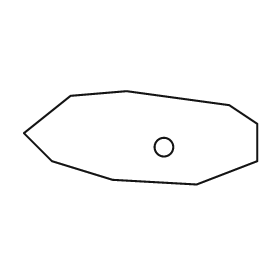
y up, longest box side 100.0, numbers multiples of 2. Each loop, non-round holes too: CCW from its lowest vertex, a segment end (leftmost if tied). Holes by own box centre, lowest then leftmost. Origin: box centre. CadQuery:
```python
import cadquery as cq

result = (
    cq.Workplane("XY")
    .moveTo(24.0, -20.0)
    .lineTo(50.0, -10.0)
    .lineTo(50.0, 6.0)
    .lineTo(38.0, 14.0)
    .lineTo(-6.0, 20.0)
    .lineTo(-30.0, 18.0)
    .lineTo(-50.0, 2.0)
    .lineTo(-38.0, -10.0)
    .lineTo(-12.0, -18.0)
    .close()
    .moveTo(10.0, -4.0)
    .circle(4.0)
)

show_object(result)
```